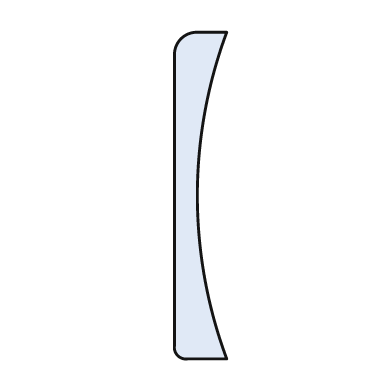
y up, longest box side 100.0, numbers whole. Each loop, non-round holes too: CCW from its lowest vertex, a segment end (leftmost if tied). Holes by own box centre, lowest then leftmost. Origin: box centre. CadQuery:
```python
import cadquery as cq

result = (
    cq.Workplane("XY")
    .moveTo(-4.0, -50.0)
    .lineTo(8.0, -50.0)
    .threePointArc((-1.0, 0.0), (8.0, 50.0))
    .lineTo(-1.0, 50.0)
    .threePointArc((-6.0, 48.0), (-8.0, 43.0))
    .lineTo(-8.0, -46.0)
    .threePointArc((-7.0, -49.0), (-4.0, -50.0))
    .close()
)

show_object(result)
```